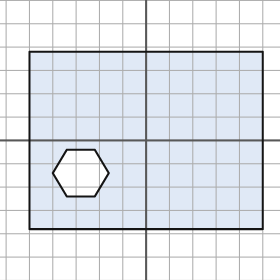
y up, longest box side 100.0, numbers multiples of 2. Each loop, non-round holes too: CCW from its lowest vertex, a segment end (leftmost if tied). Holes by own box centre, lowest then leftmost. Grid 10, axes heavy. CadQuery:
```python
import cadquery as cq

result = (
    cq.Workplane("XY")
    .moveTo(-50.0, -38.0)
    .lineTo(50.0, -38.0)
    .lineTo(50.0, 38.0)
    .lineTo(-50.0, 38.0)
    .close()
    .moveTo(-34.0, -24.0)
    .lineTo(-22.0, -24.0)
    .lineTo(-16.0, -14.0)
    .lineTo(-22.0, -4.0)
    .lineTo(-34.0, -4.0)
    .lineTo(-40.0, -14.0)
    .close()
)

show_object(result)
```